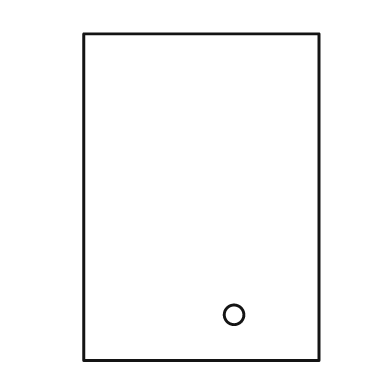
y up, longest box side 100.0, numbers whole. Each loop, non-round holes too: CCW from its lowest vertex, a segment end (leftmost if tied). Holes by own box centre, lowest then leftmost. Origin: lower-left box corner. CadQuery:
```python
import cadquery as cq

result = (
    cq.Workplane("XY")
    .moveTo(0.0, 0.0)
    .lineTo(72.0, 0.0)
    .lineTo(72.0, 100.0)
    .lineTo(0.0, 100.0)
    .close()
    .moveTo(46.0, 14.0)
    .circle(3.0)
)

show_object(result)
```